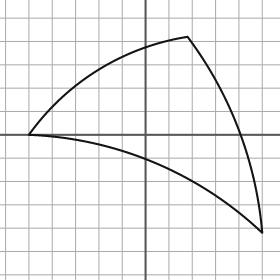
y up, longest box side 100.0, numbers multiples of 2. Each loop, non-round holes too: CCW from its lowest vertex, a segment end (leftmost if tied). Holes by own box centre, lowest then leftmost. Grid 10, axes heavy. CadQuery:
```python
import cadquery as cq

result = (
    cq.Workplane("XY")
    .moveTo(50.0, -42.0)
    .threePointArc((40.0, 2.0), (18.0, 42.0))
    .threePointArc((-20.0, 28.0), (-50.0, 0.0))
    .threePointArc((4.0, -12.0), (50.0, -42.0))
    .close()
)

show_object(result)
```